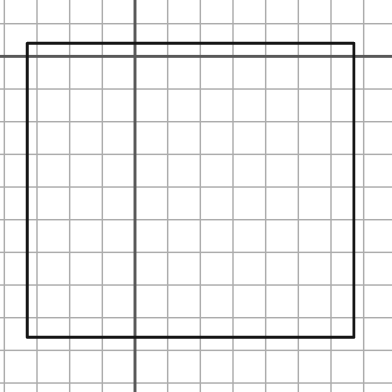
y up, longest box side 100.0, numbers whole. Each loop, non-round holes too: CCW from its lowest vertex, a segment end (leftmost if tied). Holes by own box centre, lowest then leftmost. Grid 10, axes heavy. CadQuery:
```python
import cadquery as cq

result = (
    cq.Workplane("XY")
    .moveTo(-33.0, -86.0)
    .lineTo(67.0, -86.0)
    .lineTo(67.0, 4.0)
    .lineTo(-33.0, 4.0)
    .close()
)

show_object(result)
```